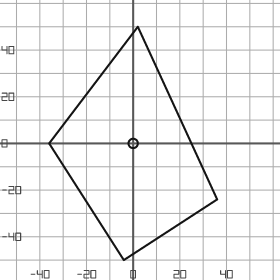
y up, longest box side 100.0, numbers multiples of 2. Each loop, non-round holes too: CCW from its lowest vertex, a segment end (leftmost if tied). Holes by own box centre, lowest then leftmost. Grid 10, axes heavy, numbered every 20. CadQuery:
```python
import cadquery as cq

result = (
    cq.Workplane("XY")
    .moveTo(-4.0, -50.0)
    .lineTo(36.0, -24.0)
    .lineTo(2.0, 50.0)
    .lineTo(-36.0, 0.0)
    .close()
    .moveTo(0.0, 0.0)
    .circle(2.0)
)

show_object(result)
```